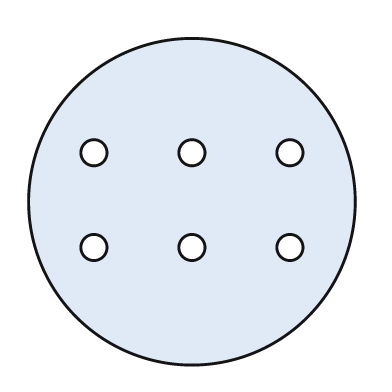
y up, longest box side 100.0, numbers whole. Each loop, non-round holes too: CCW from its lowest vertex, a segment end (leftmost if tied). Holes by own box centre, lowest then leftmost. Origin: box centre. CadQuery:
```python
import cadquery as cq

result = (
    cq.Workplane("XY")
    .moveTo(0.0, 0.0)
    .circle(50.0)
    .moveTo(-30.0, -14.0)
    .circle(4.0)
    .moveTo(0.0, -14.0)
    .circle(4.0)
    .moveTo(30.0, -14.0)
    .circle(4.0)
    .moveTo(-30.0, 15.0)
    .circle(4.0)
    .moveTo(0.0, 15.0)
    .circle(4.0)
    .moveTo(30.0, 15.0)
    .circle(4.0)
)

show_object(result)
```